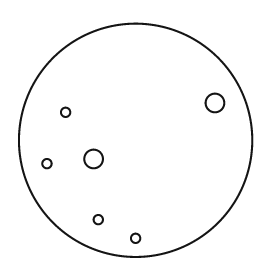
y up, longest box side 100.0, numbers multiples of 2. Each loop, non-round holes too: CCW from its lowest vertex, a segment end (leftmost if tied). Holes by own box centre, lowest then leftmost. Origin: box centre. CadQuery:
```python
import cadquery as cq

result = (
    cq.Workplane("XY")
    .moveTo(0.0, 0.0)
    .circle(50.0)
    .moveTo(0.0, -42.0)
    .circle(2.0)
    .moveTo(-16.0, -34.0)
    .circle(2.0)
    .moveTo(-38.0, -10.0)
    .circle(2.0)
    .moveTo(-18.0, -8.0)
    .circle(4.0)
    .moveTo(-30.0, 12.0)
    .circle(2.0)
    .moveTo(34.0, 16.0)
    .circle(4.0)
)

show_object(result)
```